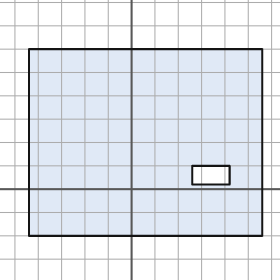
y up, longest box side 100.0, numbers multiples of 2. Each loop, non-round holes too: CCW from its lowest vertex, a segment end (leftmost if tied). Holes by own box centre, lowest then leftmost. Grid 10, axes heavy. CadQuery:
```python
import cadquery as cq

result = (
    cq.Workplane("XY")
    .moveTo(-44.0, -20.0)
    .lineTo(56.0, -20.0)
    .lineTo(56.0, 60.0)
    .lineTo(-44.0, 60.0)
    .close()
    .moveTo(26.0, 2.0)
    .lineTo(42.0, 2.0)
    .lineTo(42.0, 10.0)
    .lineTo(26.0, 10.0)
    .close()
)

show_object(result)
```